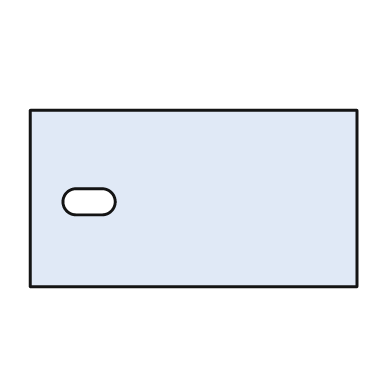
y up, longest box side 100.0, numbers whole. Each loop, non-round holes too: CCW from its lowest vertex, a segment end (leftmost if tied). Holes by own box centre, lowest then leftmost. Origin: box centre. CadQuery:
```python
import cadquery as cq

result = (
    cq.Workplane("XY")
    .moveTo(-50.0, -27.0)
    .lineTo(50.0, -27.0)
    .lineTo(50.0, 27.0)
    .lineTo(-50.0, 27.0)
    .close()
    .moveTo(-36.0, -5.0)
    .lineTo(-28.0, -5.0)
    .threePointArc((-24.0, -1.0), (-28.0, 3.0))
    .lineTo(-36.0, 3.0)
    .threePointArc((-40.0, -1.0), (-36.0, -5.0))
    .close()
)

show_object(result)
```